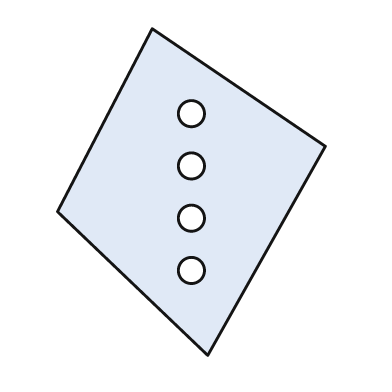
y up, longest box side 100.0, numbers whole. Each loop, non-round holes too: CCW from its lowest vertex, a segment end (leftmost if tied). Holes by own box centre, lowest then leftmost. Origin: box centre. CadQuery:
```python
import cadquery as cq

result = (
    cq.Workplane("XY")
    .moveTo(5.0, -50.0)
    .lineTo(41.0, 14.0)
    .lineTo(-12.0, 50.0)
    .lineTo(-41.0, -6.0)
    .close()
    .moveTo(0.0, -24.0)
    .circle(4.0)
    .moveTo(0.0, -8.0)
    .circle(4.0)
    .moveTo(0.0, 8.0)
    .circle(4.0)
    .moveTo(0.0, 24.0)
    .circle(4.0)
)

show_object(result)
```